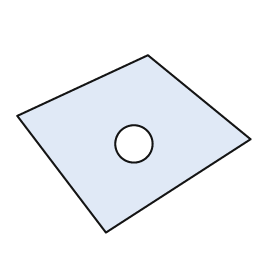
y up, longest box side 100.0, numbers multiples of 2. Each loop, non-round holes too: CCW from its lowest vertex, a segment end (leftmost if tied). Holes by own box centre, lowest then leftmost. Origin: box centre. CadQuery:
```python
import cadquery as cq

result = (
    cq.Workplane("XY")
    .moveTo(-12.0, -38.0)
    .lineTo(50.0, 2.0)
    .lineTo(6.0, 38.0)
    .lineTo(-50.0, 12.0)
    .close()
    .moveTo(0.0, 0.0)
    .circle(8.0)
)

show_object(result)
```